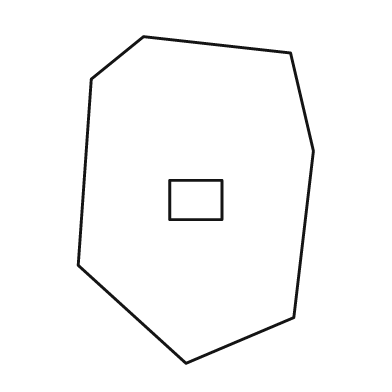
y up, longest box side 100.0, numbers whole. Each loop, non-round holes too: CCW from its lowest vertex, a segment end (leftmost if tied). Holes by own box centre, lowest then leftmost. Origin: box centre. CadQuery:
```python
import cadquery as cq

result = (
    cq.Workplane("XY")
    .moveTo(-3.0, -50.0)
    .lineTo(30.0, -36.0)
    .lineTo(36.0, 15.0)
    .lineTo(29.0, 45.0)
    .lineTo(-16.0, 50.0)
    .lineTo(-32.0, 37.0)
    .lineTo(-36.0, -20.0)
    .close()
    .moveTo(-8.0, -6.0)
    .lineTo(8.0, -6.0)
    .lineTo(8.0, 6.0)
    .lineTo(-8.0, 6.0)
    .close()
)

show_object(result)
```